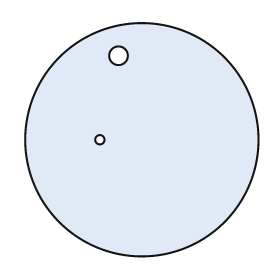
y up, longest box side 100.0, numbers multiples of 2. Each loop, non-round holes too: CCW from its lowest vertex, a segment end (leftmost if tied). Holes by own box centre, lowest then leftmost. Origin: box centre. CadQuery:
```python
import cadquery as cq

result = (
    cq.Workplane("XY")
    .moveTo(0.0, 0.0)
    .circle(50.0)
    .moveTo(-18.0, 0.0)
    .circle(2.0)
    .moveTo(-10.0, 36.0)
    .circle(4.0)
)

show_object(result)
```